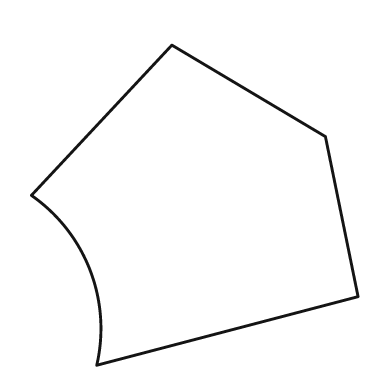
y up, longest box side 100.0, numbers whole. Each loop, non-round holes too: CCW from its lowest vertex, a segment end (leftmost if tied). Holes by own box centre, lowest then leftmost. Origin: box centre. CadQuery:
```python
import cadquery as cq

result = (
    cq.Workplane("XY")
    .moveTo(-30.0, -49.0)
    .lineTo(50.0, -28.0)
    .lineTo(40.0, 21.0)
    .lineTo(-7.0, 49.0)
    .lineTo(-50.0, 3.0)
    .threePointArc((-32.0, -20.0), (-30.0, -49.0))
    .close()
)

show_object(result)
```